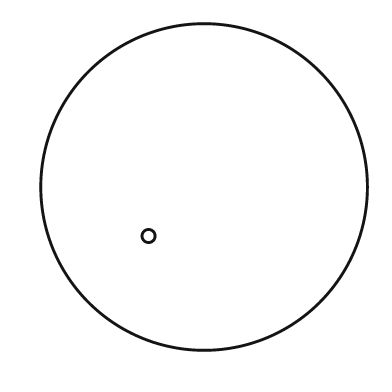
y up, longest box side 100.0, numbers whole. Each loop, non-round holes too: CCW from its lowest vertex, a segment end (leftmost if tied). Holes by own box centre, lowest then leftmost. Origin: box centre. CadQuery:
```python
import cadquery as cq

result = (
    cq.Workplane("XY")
    .moveTo(0.0, 0.0)
    .circle(50.0)
    .moveTo(-17.0, -15.0)
    .circle(2.0)
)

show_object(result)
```